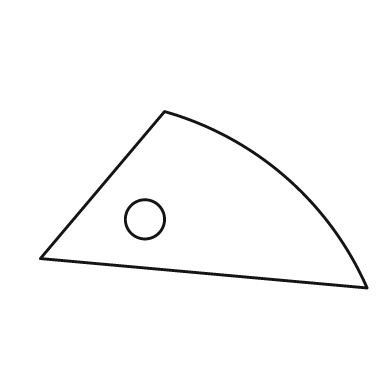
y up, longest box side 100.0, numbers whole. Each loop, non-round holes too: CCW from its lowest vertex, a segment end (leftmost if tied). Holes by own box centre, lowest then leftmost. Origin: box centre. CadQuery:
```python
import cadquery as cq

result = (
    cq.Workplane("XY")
    .moveTo(50.0, -27.0)
    .threePointArc((25.0, 7.0), (-12.0, 27.0))
    .lineTo(-50.0, -18.0)
    .close()
    .moveTo(-18.0, -6.0)
    .circle(6.0)
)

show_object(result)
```